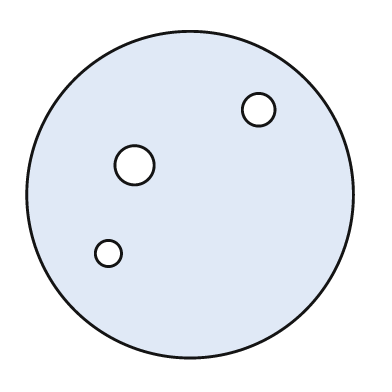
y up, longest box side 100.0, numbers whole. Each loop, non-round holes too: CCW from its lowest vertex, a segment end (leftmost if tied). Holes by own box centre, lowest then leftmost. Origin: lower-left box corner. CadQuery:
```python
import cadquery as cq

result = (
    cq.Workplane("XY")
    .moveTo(50.0, 50.0)
    .circle(50.0)
    .moveTo(25.0, 32.0)
    .circle(4.0)
    .moveTo(33.0, 59.0)
    .circle(6.0)
    .moveTo(71.0, 76.0)
    .circle(5.0)
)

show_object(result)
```